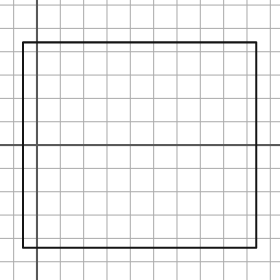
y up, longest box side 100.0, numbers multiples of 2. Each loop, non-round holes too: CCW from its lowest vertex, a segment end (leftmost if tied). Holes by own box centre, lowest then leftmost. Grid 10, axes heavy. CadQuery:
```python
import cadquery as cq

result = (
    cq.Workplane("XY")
    .moveTo(-6.0, -44.0)
    .lineTo(94.0, -44.0)
    .lineTo(94.0, 44.0)
    .lineTo(-6.0, 44.0)
    .close()
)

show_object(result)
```